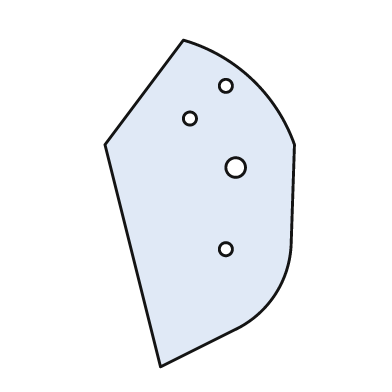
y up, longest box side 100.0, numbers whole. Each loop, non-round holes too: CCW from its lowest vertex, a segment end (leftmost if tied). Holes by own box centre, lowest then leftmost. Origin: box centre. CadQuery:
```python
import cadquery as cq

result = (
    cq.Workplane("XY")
    .moveTo(-12.0, -50.0)
    .lineTo(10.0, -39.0)
    .threePointArc((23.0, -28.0), (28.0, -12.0))
    .lineTo(29.0, 18.0)
    .threePointArc((16.0, 38.0), (-5.0, 50.0))
    .lineTo(-29.0, 18.0)
    .close()
    .moveTo(8.0, -14.0)
    .circle(2.0)
    .moveTo(11.0, 11.0)
    .circle(3.0)
    .moveTo(-3.0, 26.0)
    .circle(2.0)
    .moveTo(8.0, 36.0)
    .circle(2.0)
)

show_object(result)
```